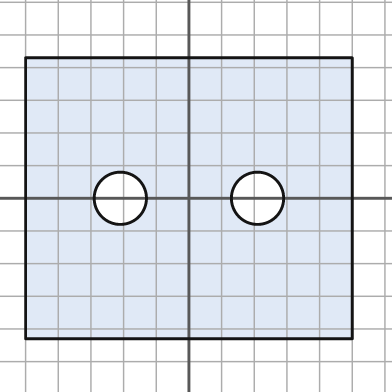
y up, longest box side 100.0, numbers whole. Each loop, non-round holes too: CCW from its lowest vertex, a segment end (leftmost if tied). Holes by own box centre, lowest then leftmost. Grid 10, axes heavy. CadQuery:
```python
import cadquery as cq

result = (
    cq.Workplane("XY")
    .moveTo(-50.0, -43.0)
    .lineTo(50.0, -43.0)
    .lineTo(50.0, 43.0)
    .lineTo(-50.0, 43.0)
    .close()
    .moveTo(-21.0, 0.0)
    .circle(8.0)
    .moveTo(21.0, 0.0)
    .circle(8.0)
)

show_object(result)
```